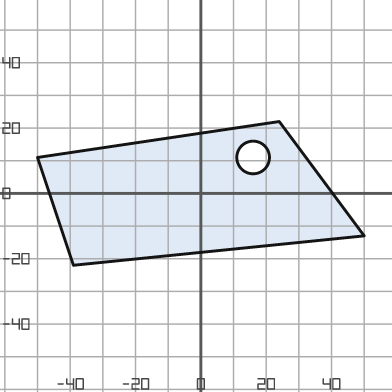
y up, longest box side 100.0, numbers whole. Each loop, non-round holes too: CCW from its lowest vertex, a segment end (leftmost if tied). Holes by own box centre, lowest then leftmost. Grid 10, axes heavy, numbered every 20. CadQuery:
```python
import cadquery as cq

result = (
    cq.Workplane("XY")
    .moveTo(-39.0, -22.0)
    .lineTo(50.0, -13.0)
    .lineTo(24.0, 22.0)
    .lineTo(-50.0, 11.0)
    .close()
    .moveTo(16.0, 11.0)
    .circle(5.0)
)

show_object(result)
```